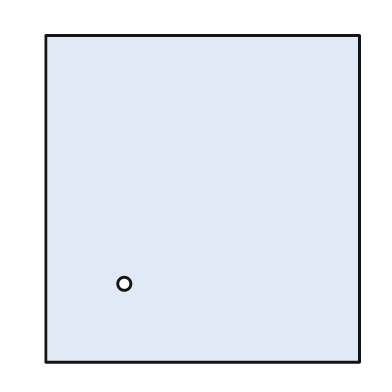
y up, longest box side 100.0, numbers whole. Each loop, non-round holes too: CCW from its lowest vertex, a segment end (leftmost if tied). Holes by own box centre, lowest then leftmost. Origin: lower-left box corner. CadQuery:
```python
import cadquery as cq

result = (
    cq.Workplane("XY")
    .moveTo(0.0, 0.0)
    .lineTo(96.0, 0.0)
    .lineTo(96.0, 100.0)
    .lineTo(0.0, 100.0)
    .close()
    .moveTo(24.0, 24.0)
    .circle(2.0)
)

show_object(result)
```